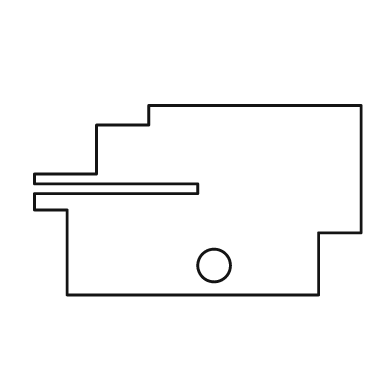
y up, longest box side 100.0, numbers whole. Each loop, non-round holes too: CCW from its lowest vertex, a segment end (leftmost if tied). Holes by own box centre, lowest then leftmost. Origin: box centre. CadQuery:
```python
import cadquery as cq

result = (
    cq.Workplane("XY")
    .moveTo(-40.0, -29.0)
    .lineTo(37.0, -29.0)
    .lineTo(37.0, -10.0)
    .lineTo(50.0, -10.0)
    .lineTo(50.0, 29.0)
    .lineTo(-15.0, 29.0)
    .lineTo(-15.0, 23.0)
    .lineTo(-31.0, 23.0)
    .lineTo(-31.0, 8.0)
    .lineTo(-50.0, 8.0)
    .lineTo(-50.0, 5.0)
    .lineTo(0.0, 5.0)
    .lineTo(0.0, 2.0)
    .lineTo(-50.0, 2.0)
    .lineTo(-50.0, -3.0)
    .lineTo(-40.0, -3.0)
    .close()
    .moveTo(5.0, -20.0)
    .circle(5.0)
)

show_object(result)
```